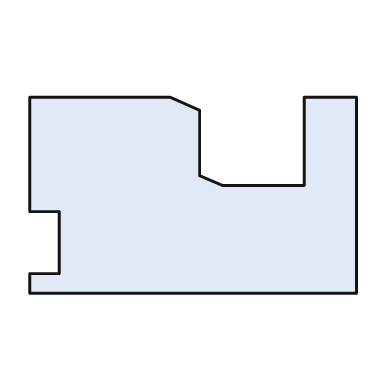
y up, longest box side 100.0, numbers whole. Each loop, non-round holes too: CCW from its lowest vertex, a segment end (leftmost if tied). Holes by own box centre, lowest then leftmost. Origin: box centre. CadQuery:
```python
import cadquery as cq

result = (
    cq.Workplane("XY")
    .moveTo(-50.0, -30.0)
    .lineTo(50.0, -30.0)
    .lineTo(50.0, 30.0)
    .lineTo(34.0, 30.0)
    .lineTo(34.0, 3.0)
    .lineTo(9.0, 3.0)
    .lineTo(2.0, 6.0)
    .lineTo(2.0, 26.0)
    .lineTo(-7.0, 30.0)
    .lineTo(-50.0, 30.0)
    .lineTo(-50.0, -5.0)
    .lineTo(-41.0, -5.0)
    .lineTo(-41.0, -24.0)
    .lineTo(-50.0, -24.0)
    .close()
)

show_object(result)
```